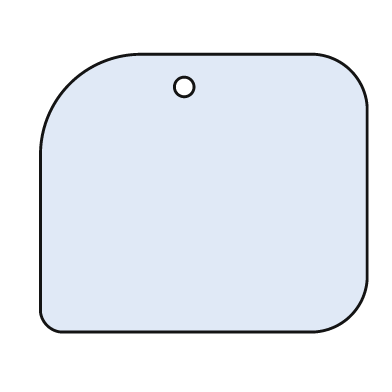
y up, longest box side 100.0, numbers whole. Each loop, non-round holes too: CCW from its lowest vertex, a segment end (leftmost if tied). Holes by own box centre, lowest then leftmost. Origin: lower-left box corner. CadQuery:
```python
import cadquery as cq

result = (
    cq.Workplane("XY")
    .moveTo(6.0, 0.0)
    .lineTo(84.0, 0.0)
    .threePointArc((95.0, 5.0), (100.0, 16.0))
    .lineTo(100.0, 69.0)
    .threePointArc((95.0, 80.0), (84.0, 85.0))
    .lineTo(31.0, 85.0)
    .threePointArc((9.0, 76.0), (0.0, 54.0))
    .lineTo(0.0, 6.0)
    .threePointArc((2.0, 2.0), (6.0, 0.0))
    .close()
    .moveTo(44.0, 75.0)
    .circle(3.0)
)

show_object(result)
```